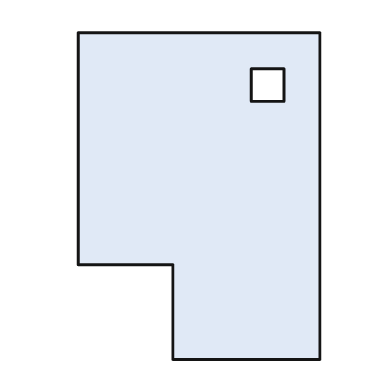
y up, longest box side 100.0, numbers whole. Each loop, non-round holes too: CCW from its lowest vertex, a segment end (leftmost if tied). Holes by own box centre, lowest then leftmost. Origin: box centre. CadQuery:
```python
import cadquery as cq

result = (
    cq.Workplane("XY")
    .moveTo(-8.0, -50.0)
    .lineTo(37.0, -50.0)
    .lineTo(37.0, 50.0)
    .lineTo(-37.0, 50.0)
    .lineTo(-37.0, -21.0)
    .lineTo(-8.0, -21.0)
    .close()
    .moveTo(16.0, 29.0)
    .lineTo(26.0, 29.0)
    .lineTo(26.0, 39.0)
    .lineTo(16.0, 39.0)
    .close()
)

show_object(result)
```